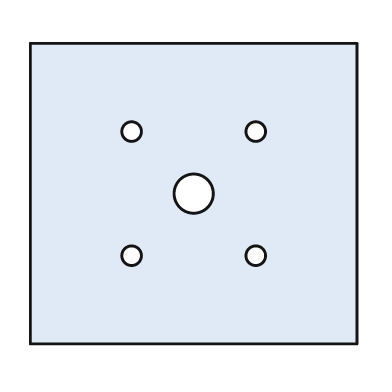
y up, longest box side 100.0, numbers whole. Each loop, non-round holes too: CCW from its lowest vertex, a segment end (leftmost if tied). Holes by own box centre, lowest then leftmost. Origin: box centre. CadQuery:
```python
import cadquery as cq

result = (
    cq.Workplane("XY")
    .moveTo(-50.0, -46.0)
    .lineTo(50.0, -46.0)
    .lineTo(50.0, 46.0)
    .lineTo(-50.0, 46.0)
    .close()
    .moveTo(-19.0, -19.0)
    .circle(3.0)
    .moveTo(19.0, -19.0)
    .circle(3.0)
    .moveTo(0.0, 0.0)
    .circle(6.0)
    .moveTo(-19.0, 19.0)
    .circle(3.0)
    .moveTo(19.0, 19.0)
    .circle(3.0)
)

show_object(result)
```